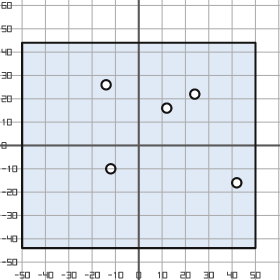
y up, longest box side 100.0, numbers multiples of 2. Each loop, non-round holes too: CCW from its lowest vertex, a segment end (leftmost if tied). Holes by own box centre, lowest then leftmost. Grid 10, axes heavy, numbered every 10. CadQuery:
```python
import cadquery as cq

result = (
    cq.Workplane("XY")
    .moveTo(-50.0, -44.0)
    .lineTo(50.0, -44.0)
    .lineTo(50.0, 44.0)
    .lineTo(-50.0, 44.0)
    .close()
    .moveTo(42.0, -16.0)
    .circle(2.0)
    .moveTo(-12.0, -10.0)
    .circle(2.0)
    .moveTo(12.0, 16.0)
    .circle(2.0)
    .moveTo(24.0, 22.0)
    .circle(2.0)
    .moveTo(-14.0, 26.0)
    .circle(2.0)
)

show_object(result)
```